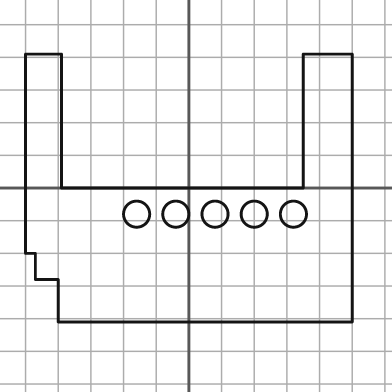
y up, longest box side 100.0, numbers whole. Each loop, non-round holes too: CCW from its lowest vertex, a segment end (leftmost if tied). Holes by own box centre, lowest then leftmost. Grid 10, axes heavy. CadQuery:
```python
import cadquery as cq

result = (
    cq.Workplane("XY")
    .moveTo(-40.0, -41.0)
    .lineTo(50.0, -41.0)
    .lineTo(50.0, 41.0)
    .lineTo(35.0, 41.0)
    .lineTo(35.0, 0.0)
    .lineTo(-39.0, 0.0)
    .lineTo(-39.0, 41.0)
    .lineTo(-50.0, 41.0)
    .lineTo(-50.0, -20.0)
    .lineTo(-47.0, -20.0)
    .lineTo(-47.0, -28.0)
    .lineTo(-40.0, -28.0)
    .close()
    .moveTo(-16.0, -8.0)
    .circle(4.0)
    .moveTo(-4.0, -8.0)
    .circle(4.0)
    .moveTo(8.0, -8.0)
    .circle(4.0)
    .moveTo(20.0, -8.0)
    .circle(4.0)
    .moveTo(32.0, -8.0)
    .circle(4.0)
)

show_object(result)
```